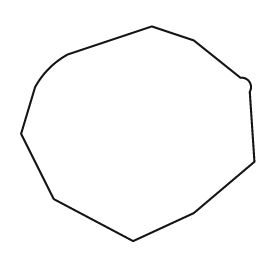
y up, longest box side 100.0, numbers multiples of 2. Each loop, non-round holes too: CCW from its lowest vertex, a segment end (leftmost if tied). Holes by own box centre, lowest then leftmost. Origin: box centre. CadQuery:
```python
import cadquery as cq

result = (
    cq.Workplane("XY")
    .moveTo(-2.0, -46.0)
    .lineTo(24.0, -34.0)
    .lineTo(50.0, -12.0)
    .lineTo(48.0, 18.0)
    .threePointArc((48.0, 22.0), (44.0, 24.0))
    .lineTo(24.0, 40.0)
    .lineTo(6.0, 46.0)
    .lineTo(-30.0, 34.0)
    .threePointArc((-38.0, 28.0), (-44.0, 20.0))
    .lineTo(-50.0, 0.0)
    .lineTo(-36.0, -28.0)
    .close()
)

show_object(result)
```